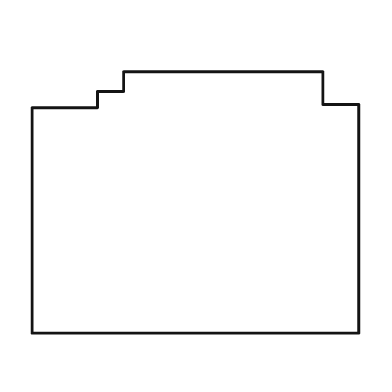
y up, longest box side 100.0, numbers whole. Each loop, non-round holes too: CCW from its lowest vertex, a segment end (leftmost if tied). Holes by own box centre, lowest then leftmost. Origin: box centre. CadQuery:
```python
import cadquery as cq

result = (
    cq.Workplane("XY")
    .moveTo(-50.0, -40.0)
    .lineTo(50.0, -40.0)
    .lineTo(50.0, 30.0)
    .lineTo(39.0, 30.0)
    .lineTo(39.0, 40.0)
    .lineTo(-22.0, 40.0)
    .lineTo(-22.0, 34.0)
    .lineTo(-30.0, 34.0)
    .lineTo(-30.0, 29.0)
    .lineTo(-50.0, 29.0)
    .close()
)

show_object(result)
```